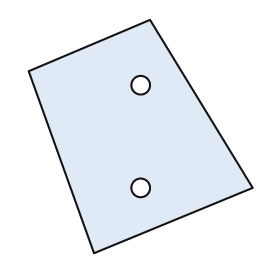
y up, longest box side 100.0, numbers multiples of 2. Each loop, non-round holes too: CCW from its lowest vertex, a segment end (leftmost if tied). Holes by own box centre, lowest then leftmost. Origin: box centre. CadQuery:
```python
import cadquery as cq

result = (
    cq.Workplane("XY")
    .moveTo(-20.0, -50.0)
    .lineTo(48.0, -22.0)
    .lineTo(4.0, 50.0)
    .lineTo(-48.0, 28.0)
    .close()
    .moveTo(0.0, -22.0)
    .circle(4.0)
    .moveTo(0.0, 22.0)
    .circle(4.0)
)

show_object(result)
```